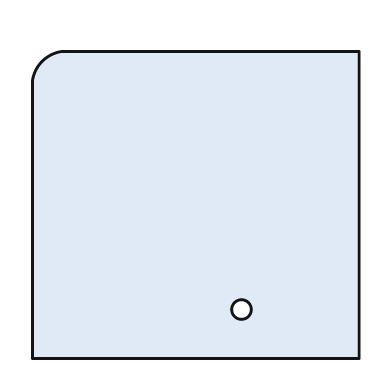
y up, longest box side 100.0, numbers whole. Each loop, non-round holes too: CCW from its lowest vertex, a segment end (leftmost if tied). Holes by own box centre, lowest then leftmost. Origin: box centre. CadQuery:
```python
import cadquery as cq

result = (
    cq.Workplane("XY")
    .moveTo(-50.0, -47.0)
    .lineTo(50.0, -47.0)
    .lineTo(50.0, 47.0)
    .lineTo(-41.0, 47.0)
    .threePointArc((-47.0, 44.0), (-50.0, 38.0))
    .close()
    .moveTo(14.0, -32.0)
    .circle(3.0)
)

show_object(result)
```